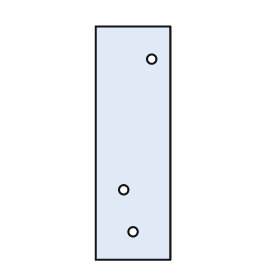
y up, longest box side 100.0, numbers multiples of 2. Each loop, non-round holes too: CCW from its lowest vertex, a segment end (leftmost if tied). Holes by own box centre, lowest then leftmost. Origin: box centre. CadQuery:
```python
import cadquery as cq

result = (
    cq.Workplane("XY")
    .moveTo(-16.0, -50.0)
    .lineTo(16.0, -50.0)
    .lineTo(16.0, 50.0)
    .lineTo(-16.0, 50.0)
    .close()
    .moveTo(0.0, -38.0)
    .circle(2.0)
    .moveTo(-4.0, -20.0)
    .circle(2.0)
    .moveTo(8.0, 36.0)
    .circle(2.0)
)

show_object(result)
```